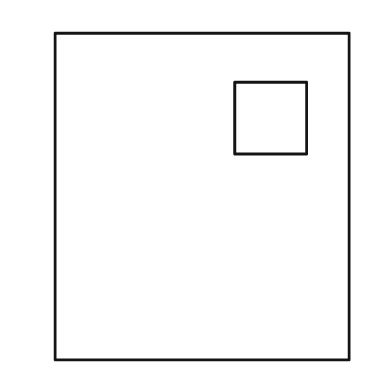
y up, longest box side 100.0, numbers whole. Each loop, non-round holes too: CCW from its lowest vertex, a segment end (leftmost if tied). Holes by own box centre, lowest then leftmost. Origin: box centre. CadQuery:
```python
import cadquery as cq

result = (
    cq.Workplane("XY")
    .moveTo(-45.0, -50.0)
    .lineTo(45.0, -50.0)
    .lineTo(45.0, 50.0)
    .lineTo(-45.0, 50.0)
    .close()
    .moveTo(10.0, 13.0)
    .lineTo(32.0, 13.0)
    .lineTo(32.0, 35.0)
    .lineTo(10.0, 35.0)
    .close()
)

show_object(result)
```